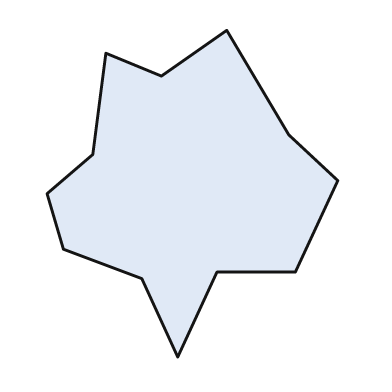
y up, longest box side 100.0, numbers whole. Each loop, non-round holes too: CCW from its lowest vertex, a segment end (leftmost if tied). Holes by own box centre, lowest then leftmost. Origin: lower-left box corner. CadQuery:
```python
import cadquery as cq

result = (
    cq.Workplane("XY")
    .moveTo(40.0, 0.0)
    .lineTo(52.0, 26.0)
    .lineTo(76.0, 26.0)
    .lineTo(89.0, 54.0)
    .lineTo(74.0, 68.0)
    .lineTo(55.0, 100.0)
    .lineTo(35.0, 86.0)
    .lineTo(18.0, 93.0)
    .lineTo(14.0, 62.0)
    .lineTo(0.0, 50.0)
    .lineTo(5.0, 33.0)
    .lineTo(29.0, 24.0)
    .close()
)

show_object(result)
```